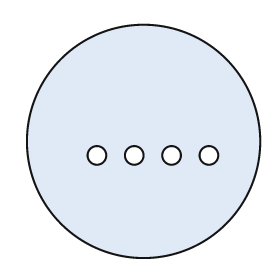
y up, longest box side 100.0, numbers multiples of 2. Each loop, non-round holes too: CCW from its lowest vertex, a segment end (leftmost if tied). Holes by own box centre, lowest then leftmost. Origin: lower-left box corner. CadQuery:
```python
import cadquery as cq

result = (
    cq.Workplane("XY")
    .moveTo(50.0, 50.0)
    .circle(50.0)
    .moveTo(30.0, 44.0)
    .circle(4.0)
    .moveTo(46.0, 44.0)
    .circle(4.0)
    .moveTo(62.0, 44.0)
    .circle(4.0)
    .moveTo(78.0, 44.0)
    .circle(4.0)
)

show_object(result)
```